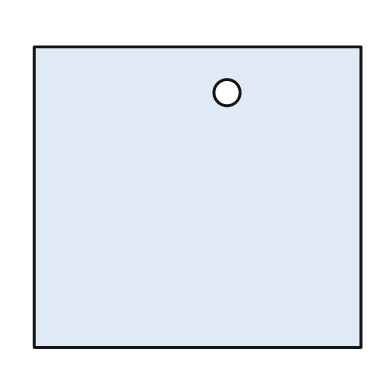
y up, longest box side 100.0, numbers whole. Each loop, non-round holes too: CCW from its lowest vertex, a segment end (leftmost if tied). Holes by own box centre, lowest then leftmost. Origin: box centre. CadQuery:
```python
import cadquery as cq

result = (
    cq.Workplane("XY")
    .moveTo(-50.0, -46.0)
    .lineTo(50.0, -46.0)
    .lineTo(50.0, 46.0)
    .lineTo(-50.0, 46.0)
    .close()
    .moveTo(9.0, 32.0)
    .circle(4.0)
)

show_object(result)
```